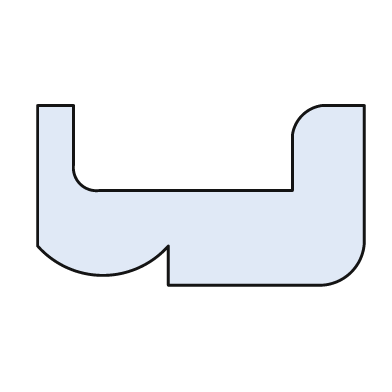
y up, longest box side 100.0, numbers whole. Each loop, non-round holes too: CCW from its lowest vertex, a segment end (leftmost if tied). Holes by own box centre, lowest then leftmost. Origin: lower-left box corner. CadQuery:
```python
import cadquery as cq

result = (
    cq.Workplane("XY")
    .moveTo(40.0, 0.0)
    .lineTo(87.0, 0.0)
    .threePointArc((96.0, 4.0), (100.0, 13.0))
    .lineTo(100.0, 55.0)
    .lineTo(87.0, 55.0)
    .threePointArc((81.0, 52.0), (78.0, 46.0))
    .lineTo(78.0, 29.0)
    .lineTo(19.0, 29.0)
    .threePointArc((13.0, 31.0), (11.0, 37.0))
    .lineTo(11.0, 55.0)
    .lineTo(0.0, 55.0)
    .lineTo(0.0, 12.0)
    .threePointArc((20.0, 3.0), (40.0, 12.0))
    .close()
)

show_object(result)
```